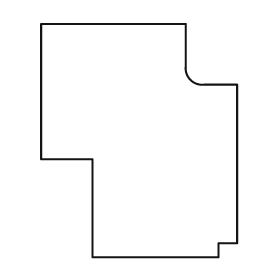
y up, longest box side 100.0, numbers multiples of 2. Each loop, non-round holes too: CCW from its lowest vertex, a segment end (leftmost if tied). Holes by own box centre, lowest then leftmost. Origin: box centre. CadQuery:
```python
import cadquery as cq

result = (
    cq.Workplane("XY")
    .moveTo(-20.0, -50.0)
    .lineTo(34.0, -50.0)
    .lineTo(34.0, -44.0)
    .lineTo(42.0, -44.0)
    .lineTo(42.0, 24.0)
    .lineTo(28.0, 24.0)
    .threePointArc((22.0, 26.0), (20.0, 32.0))
    .lineTo(20.0, 50.0)
    .lineTo(-42.0, 50.0)
    .lineTo(-42.0, -8.0)
    .lineTo(-20.0, -8.0)
    .close()
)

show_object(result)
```